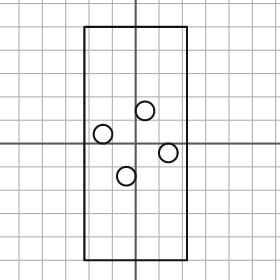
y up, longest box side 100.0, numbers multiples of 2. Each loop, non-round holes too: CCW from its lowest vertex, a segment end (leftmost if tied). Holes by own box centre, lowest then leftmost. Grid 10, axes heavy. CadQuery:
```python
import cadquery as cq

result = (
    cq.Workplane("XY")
    .moveTo(-22.0, -50.0)
    .lineTo(22.0, -50.0)
    .lineTo(22.0, 50.0)
    .lineTo(-22.0, 50.0)
    .close()
    .moveTo(-4.0, -14.0)
    .circle(4.0)
    .moveTo(14.0, -4.0)
    .circle(4.0)
    .moveTo(-14.0, 4.0)
    .circle(4.0)
    .moveTo(4.0, 14.0)
    .circle(4.0)
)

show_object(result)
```